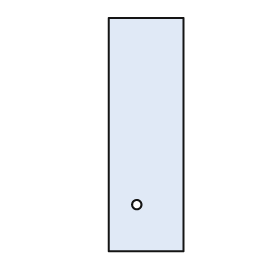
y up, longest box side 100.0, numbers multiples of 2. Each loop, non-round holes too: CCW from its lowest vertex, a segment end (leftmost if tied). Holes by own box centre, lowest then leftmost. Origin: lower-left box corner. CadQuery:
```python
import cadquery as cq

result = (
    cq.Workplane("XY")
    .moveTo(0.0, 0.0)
    .lineTo(32.0, 0.0)
    .lineTo(32.0, 100.0)
    .lineTo(0.0, 100.0)
    .close()
    .moveTo(12.0, 20.0)
    .circle(2.0)
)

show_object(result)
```